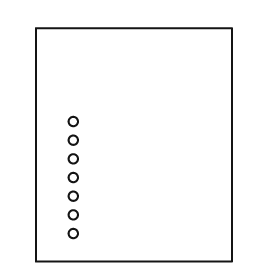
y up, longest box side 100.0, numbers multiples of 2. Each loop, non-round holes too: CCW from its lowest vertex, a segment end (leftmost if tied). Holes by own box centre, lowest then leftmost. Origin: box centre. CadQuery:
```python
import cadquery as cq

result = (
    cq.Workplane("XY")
    .moveTo(-42.0, -50.0)
    .lineTo(42.0, -50.0)
    .lineTo(42.0, 50.0)
    .lineTo(-42.0, 50.0)
    .close()
    .moveTo(-26.0, -38.0)
    .circle(2.0)
    .moveTo(-26.0, -30.0)
    .circle(2.0)
    .moveTo(-26.0, -22.0)
    .circle(2.0)
    .moveTo(-26.0, -14.0)
    .circle(2.0)
    .moveTo(-26.0, -6.0)
    .circle(2.0)
    .moveTo(-26.0, 2.0)
    .circle(2.0)
    .moveTo(-26.0, 10.0)
    .circle(2.0)
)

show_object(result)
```